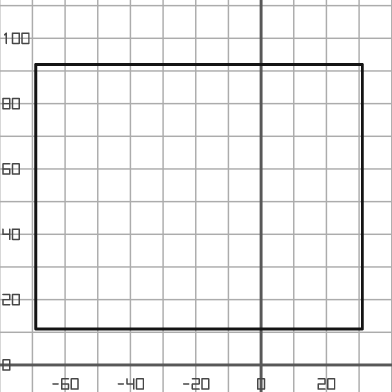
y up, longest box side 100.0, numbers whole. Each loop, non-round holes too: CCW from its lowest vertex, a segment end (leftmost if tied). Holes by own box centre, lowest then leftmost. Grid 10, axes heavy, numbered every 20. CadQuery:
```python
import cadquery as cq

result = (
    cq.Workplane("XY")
    .moveTo(-69.0, 11.0)
    .lineTo(31.0, 11.0)
    .lineTo(31.0, 92.0)
    .lineTo(-69.0, 92.0)
    .close()
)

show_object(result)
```